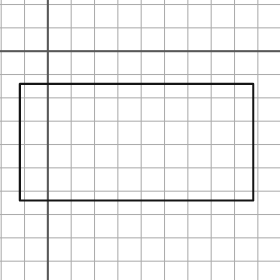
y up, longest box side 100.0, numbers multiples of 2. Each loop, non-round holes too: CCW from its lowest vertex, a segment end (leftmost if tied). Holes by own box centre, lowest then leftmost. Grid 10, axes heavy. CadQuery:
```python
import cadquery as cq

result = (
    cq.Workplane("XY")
    .moveTo(-12.0, -64.0)
    .lineTo(88.0, -64.0)
    .lineTo(88.0, -14.0)
    .lineTo(-12.0, -14.0)
    .close()
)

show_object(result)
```